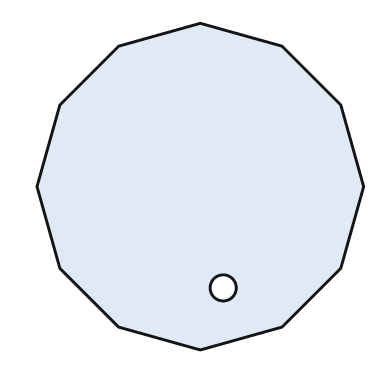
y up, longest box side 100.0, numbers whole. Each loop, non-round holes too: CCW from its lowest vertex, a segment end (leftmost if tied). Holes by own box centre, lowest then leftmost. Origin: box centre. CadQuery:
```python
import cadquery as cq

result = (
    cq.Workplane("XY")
    .moveTo(0.0, -50.0)
    .lineTo(25.0, -43.0)
    .lineTo(43.0, -25.0)
    .lineTo(50.0, 0.0)
    .lineTo(43.0, 25.0)
    .lineTo(25.0, 43.0)
    .lineTo(0.0, 50.0)
    .lineTo(-25.0, 43.0)
    .lineTo(-43.0, 25.0)
    .lineTo(-50.0, 0.0)
    .lineTo(-43.0, -25.0)
    .lineTo(-25.0, -43.0)
    .close()
    .moveTo(7.0, -31.0)
    .circle(4.0)
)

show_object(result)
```